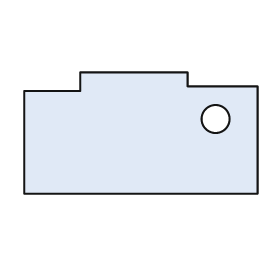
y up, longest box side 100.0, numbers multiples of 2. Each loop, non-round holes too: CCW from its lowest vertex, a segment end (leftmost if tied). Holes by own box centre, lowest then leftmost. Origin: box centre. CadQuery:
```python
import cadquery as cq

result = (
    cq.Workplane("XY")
    .moveTo(-50.0, -26.0)
    .lineTo(50.0, -26.0)
    .lineTo(50.0, 20.0)
    .lineTo(20.0, 20.0)
    .lineTo(20.0, 26.0)
    .lineTo(-26.0, 26.0)
    .lineTo(-26.0, 18.0)
    .lineTo(-50.0, 18.0)
    .close()
    .moveTo(32.0, 6.0)
    .circle(6.0)
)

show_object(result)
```